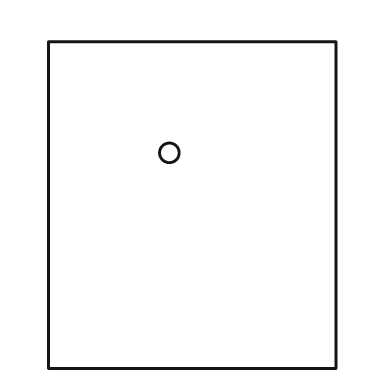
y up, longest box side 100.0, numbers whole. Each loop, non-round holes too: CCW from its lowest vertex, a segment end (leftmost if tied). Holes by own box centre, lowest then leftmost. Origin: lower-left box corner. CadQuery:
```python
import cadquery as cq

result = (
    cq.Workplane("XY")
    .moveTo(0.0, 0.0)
    .lineTo(88.0, 0.0)
    .lineTo(88.0, 100.0)
    .lineTo(0.0, 100.0)
    .close()
    .moveTo(37.0, 66.0)
    .circle(3.0)
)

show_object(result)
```